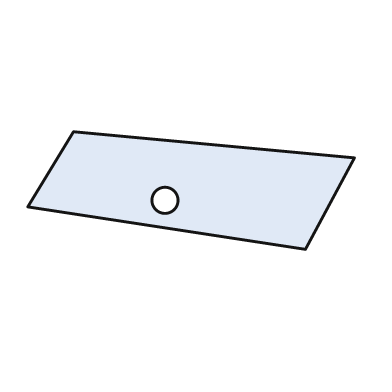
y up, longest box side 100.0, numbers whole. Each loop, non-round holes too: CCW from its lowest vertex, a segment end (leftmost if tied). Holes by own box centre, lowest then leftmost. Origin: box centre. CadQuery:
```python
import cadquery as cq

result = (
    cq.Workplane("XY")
    .moveTo(35.0, -18.0)
    .lineTo(50.0, 10.0)
    .lineTo(-36.0, 18.0)
    .lineTo(-50.0, -5.0)
    .close()
    .moveTo(-8.0, -3.0)
    .circle(4.0)
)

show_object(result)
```